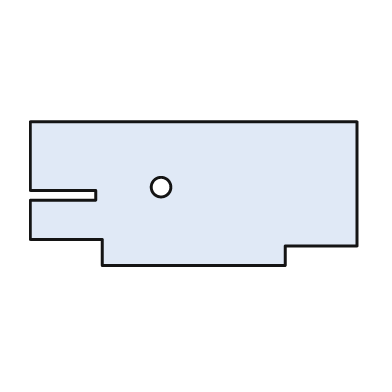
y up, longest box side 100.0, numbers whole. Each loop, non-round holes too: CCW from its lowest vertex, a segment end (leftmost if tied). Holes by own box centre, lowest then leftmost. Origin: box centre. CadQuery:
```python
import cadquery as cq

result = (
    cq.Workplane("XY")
    .moveTo(-28.0, -22.0)
    .lineTo(28.0, -22.0)
    .lineTo(28.0, -16.0)
    .lineTo(50.0, -16.0)
    .lineTo(50.0, 22.0)
    .lineTo(-50.0, 22.0)
    .lineTo(-50.0, 1.0)
    .lineTo(-30.0, 1.0)
    .lineTo(-30.0, -2.0)
    .lineTo(-50.0, -2.0)
    .lineTo(-50.0, -14.0)
    .lineTo(-28.0, -14.0)
    .close()
    .moveTo(-10.0, 2.0)
    .circle(3.0)
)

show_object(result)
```